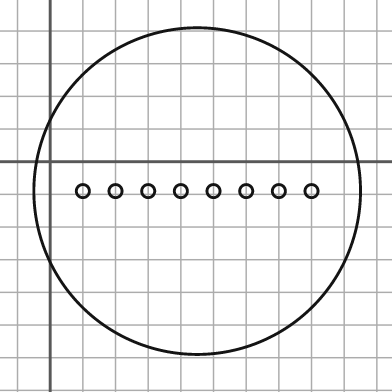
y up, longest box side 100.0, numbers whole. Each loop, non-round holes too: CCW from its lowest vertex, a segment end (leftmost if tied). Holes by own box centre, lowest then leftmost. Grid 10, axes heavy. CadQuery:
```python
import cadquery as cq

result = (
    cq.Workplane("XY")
    .moveTo(45.0, -9.0)
    .circle(50.0)
    .moveTo(10.0, -9.0)
    .circle(2.0)
    .moveTo(20.0, -9.0)
    .circle(2.0)
    .moveTo(30.0, -9.0)
    .circle(2.0)
    .moveTo(40.0, -9.0)
    .circle(2.0)
    .moveTo(50.0, -9.0)
    .circle(2.0)
    .moveTo(60.0, -9.0)
    .circle(2.0)
    .moveTo(70.0, -9.0)
    .circle(2.0)
    .moveTo(80.0, -9.0)
    .circle(2.0)
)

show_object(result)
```